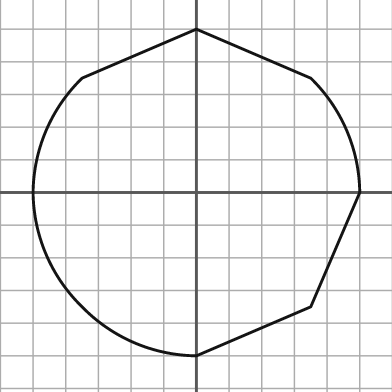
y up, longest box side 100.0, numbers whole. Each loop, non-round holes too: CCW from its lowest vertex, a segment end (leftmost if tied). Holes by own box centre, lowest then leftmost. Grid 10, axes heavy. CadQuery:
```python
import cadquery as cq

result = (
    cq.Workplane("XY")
    .moveTo(0.0, -50.0)
    .lineTo(35.0, -35.0)
    .lineTo(50.0, 0.0)
    .threePointArc((46.0, 19.0), (35.0, 35.0))
    .lineTo(0.0, 50.0)
    .lineTo(-35.0, 35.0)
    .threePointArc((-46.0, 19.0), (-50.0, 0.0))
    .threePointArc((-46.0, -19.0), (-35.0, -35.0))
    .threePointArc((-19.0, -46.0), (0.0, -50.0))
    .close()
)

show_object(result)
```